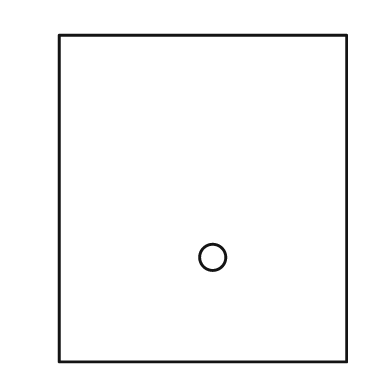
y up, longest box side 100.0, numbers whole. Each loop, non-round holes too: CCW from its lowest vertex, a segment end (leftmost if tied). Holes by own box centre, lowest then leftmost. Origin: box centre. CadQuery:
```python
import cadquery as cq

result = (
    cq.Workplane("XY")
    .moveTo(-44.0, -50.0)
    .lineTo(44.0, -50.0)
    .lineTo(44.0, 50.0)
    .lineTo(-44.0, 50.0)
    .close()
    .moveTo(3.0, -18.0)
    .circle(4.0)
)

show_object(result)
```